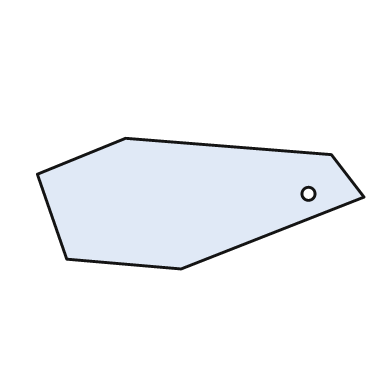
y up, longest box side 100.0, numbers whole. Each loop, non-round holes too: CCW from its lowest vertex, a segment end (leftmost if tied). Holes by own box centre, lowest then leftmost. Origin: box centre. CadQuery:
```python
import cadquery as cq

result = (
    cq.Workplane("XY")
    .moveTo(-6.0, -20.0)
    .lineTo(50.0, 2.0)
    .lineTo(40.0, 15.0)
    .lineTo(-23.0, 20.0)
    .lineTo(-50.0, 9.0)
    .lineTo(-41.0, -17.0)
    .close()
    .moveTo(33.0, 3.0)
    .circle(2.0)
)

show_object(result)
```